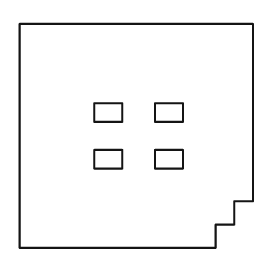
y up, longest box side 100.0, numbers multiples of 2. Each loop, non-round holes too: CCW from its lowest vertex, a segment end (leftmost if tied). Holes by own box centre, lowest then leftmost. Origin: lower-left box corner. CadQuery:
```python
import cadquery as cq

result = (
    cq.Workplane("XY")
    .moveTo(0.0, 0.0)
    .lineTo(84.0, 0.0)
    .lineTo(84.0, 10.0)
    .lineTo(92.0, 10.0)
    .lineTo(92.0, 20.0)
    .lineTo(100.0, 20.0)
    .lineTo(100.0, 96.0)
    .lineTo(0.0, 96.0)
    .close()
    .moveTo(32.0, 34.0)
    .lineTo(44.0, 34.0)
    .lineTo(44.0, 42.0)
    .lineTo(32.0, 42.0)
    .close()
    .moveTo(58.0, 34.0)
    .lineTo(70.0, 34.0)
    .lineTo(70.0, 42.0)
    .lineTo(58.0, 42.0)
    .close()
    .moveTo(32.0, 54.0)
    .lineTo(44.0, 54.0)
    .lineTo(44.0, 62.0)
    .lineTo(32.0, 62.0)
    .close()
    .moveTo(58.0, 54.0)
    .lineTo(70.0, 54.0)
    .lineTo(70.0, 62.0)
    .lineTo(58.0, 62.0)
    .close()
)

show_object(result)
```